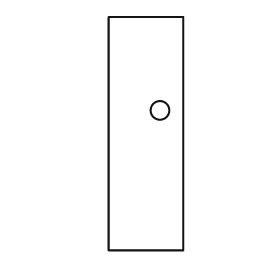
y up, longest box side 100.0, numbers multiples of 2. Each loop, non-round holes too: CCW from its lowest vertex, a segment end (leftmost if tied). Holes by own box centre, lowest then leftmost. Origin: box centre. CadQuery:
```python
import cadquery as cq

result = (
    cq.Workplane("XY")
    .moveTo(-16.0, -50.0)
    .lineTo(16.0, -50.0)
    .lineTo(16.0, 50.0)
    .lineTo(-16.0, 50.0)
    .close()
    .moveTo(6.0, 10.0)
    .circle(4.0)
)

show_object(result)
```